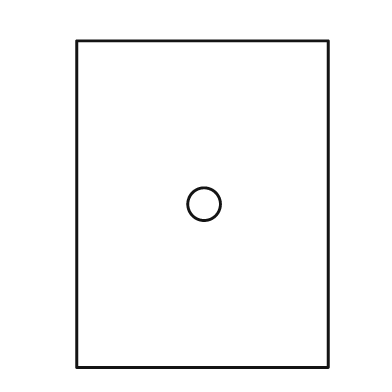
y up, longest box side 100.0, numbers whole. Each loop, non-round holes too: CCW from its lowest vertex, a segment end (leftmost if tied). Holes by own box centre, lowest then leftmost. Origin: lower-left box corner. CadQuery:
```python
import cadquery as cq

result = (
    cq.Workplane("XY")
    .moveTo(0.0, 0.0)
    .lineTo(77.0, 0.0)
    .lineTo(77.0, 100.0)
    .lineTo(0.0, 100.0)
    .close()
    .moveTo(39.0, 50.0)
    .circle(5.0)
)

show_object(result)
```